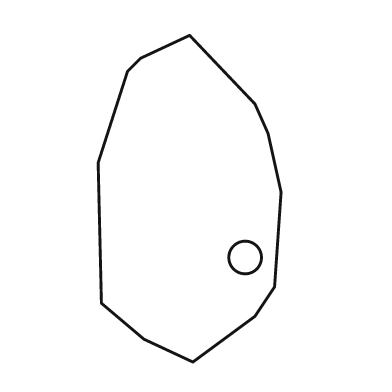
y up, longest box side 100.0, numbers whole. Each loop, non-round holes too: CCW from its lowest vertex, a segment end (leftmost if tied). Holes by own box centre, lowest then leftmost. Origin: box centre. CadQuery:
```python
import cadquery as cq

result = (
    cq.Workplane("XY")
    .moveTo(1.0, -50.0)
    .lineTo(20.0, -36.0)
    .lineTo(26.0, -27.0)
    .lineTo(28.0, 2.0)
    .lineTo(24.0, 20.0)
    .lineTo(20.0, 29.0)
    .lineTo(0.0, 50.0)
    .lineTo(-15.0, 43.0)
    .lineTo(-19.0, 39.0)
    .lineTo(-28.0, 11.0)
    .lineTo(-27.0, -32.0)
    .lineTo(-14.0, -43.0)
    .close()
    .moveTo(17.0, -18.0)
    .circle(5.0)
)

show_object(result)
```